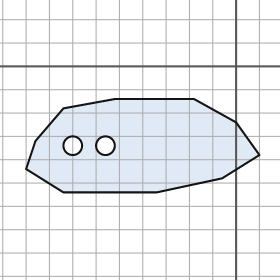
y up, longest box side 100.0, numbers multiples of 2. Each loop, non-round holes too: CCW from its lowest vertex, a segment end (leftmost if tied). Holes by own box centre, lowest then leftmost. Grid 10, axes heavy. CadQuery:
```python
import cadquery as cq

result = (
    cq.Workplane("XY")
    .moveTo(-74.0, -54.0)
    .lineTo(-34.0, -54.0)
    .lineTo(-6.0, -48.0)
    .lineTo(10.0, -38.0)
    .lineTo(0.0, -24.0)
    .lineTo(-18.0, -14.0)
    .lineTo(-52.0, -14.0)
    .lineTo(-74.0, -18.0)
    .lineTo(-86.0, -32.0)
    .lineTo(-90.0, -44.0)
    .close()
    .moveTo(-70.0, -34.0)
    .circle(4.0)
    .moveTo(-56.0, -34.0)
    .circle(4.0)
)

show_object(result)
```